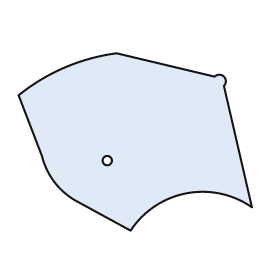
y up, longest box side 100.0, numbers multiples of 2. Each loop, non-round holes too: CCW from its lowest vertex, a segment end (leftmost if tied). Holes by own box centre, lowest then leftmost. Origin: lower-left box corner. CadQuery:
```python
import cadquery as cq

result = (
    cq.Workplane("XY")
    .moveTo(48.0, 0.0)
    .threePointArc((72.0, 16.0), (100.0, 10.0))
    .lineTo(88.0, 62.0)
    .threePointArc((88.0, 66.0), (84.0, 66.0))
    .lineTo(42.0, 76.0)
    .threePointArc((20.0, 70.0), (0.0, 58.0))
    .lineTo(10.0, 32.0)
    .threePointArc((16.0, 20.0), (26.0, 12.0))
    .close()
    .moveTo(38.0, 30.0)
    .circle(2.0)
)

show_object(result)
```